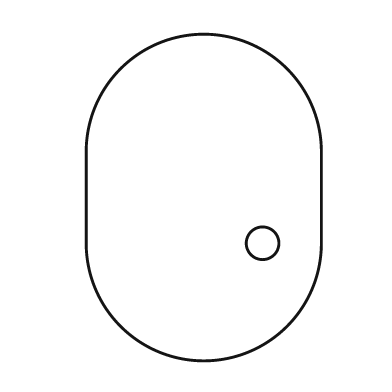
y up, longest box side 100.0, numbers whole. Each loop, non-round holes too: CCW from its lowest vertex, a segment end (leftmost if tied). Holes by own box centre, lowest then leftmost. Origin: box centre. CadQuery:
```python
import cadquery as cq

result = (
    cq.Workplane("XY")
    .moveTo(-36.0, -14.0)
    .threePointArc((0.0, -50.0), (36.0, -14.0))
    .lineTo(36.0, 14.0)
    .threePointArc((0.0, 50.0), (-36.0, 14.0))
    .close()
    .moveTo(18.0, -14.0)
    .circle(5.0)
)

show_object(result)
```